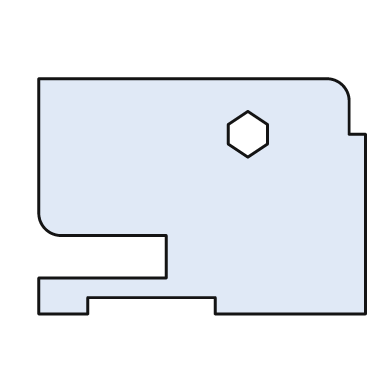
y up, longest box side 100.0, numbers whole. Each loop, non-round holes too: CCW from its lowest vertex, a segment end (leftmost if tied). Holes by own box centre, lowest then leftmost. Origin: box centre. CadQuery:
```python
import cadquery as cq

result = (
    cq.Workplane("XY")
    .moveTo(-50.0, -36.0)
    .lineTo(-35.0, -36.0)
    .lineTo(-35.0, -31.0)
    .lineTo(4.0, -31.0)
    .lineTo(4.0, -36.0)
    .lineTo(50.0, -36.0)
    .lineTo(50.0, 19.0)
    .lineTo(45.0, 19.0)
    .lineTo(45.0, 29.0)
    .threePointArc((43.0, 34.0), (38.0, 36.0))
    .lineTo(-50.0, 36.0)
    .lineTo(-50.0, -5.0)
    .threePointArc((-48.0, -10.0), (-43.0, -12.0))
    .lineTo(-11.0, -12.0)
    .lineTo(-11.0, -25.0)
    .lineTo(-50.0, -25.0)
    .close()
    .moveTo(14.0, 12.0)
    .lineTo(20.0, 16.0)
    .lineTo(20.0, 22.0)
    .lineTo(14.0, 26.0)
    .lineTo(8.0, 22.0)
    .lineTo(8.0, 16.0)
    .close()
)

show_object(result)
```